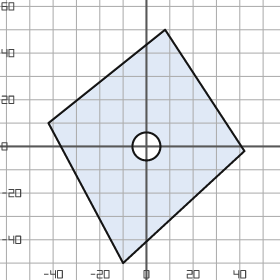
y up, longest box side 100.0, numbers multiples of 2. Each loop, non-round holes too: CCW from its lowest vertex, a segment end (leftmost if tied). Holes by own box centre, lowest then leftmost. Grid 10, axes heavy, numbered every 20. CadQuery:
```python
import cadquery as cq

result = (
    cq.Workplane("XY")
    .moveTo(-10.0, -50.0)
    .lineTo(42.0, -2.0)
    .lineTo(8.0, 50.0)
    .lineTo(-42.0, 10.0)
    .close()
    .moveTo(0.0, 0.0)
    .circle(6.0)
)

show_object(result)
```